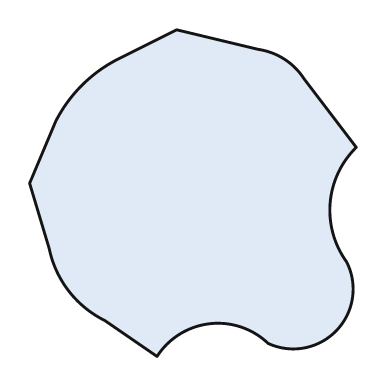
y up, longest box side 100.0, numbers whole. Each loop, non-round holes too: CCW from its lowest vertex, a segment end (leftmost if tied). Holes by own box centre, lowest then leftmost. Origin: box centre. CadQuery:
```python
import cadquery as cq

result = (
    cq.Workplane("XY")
    .moveTo(-11.0, -50.0)
    .threePointArc((5.0, -40.0), (23.0, -46.0))
    .threePointArc((44.0, -42.0), (47.0, -21.0))
    .threePointArc((42.0, -3.0), (50.0, 14.0))
    .lineTo(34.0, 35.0)
    .threePointArc((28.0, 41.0), (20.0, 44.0))
    .lineTo(-5.0, 50.0)
    .lineTo(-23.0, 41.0)
    .threePointArc((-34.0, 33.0), (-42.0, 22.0))
    .lineTo(-50.0, 3.0)
    .lineTo(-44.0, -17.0)
    .threePointArc((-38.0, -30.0), (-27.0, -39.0))
    .close()
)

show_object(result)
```